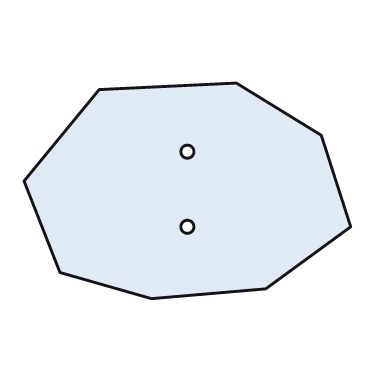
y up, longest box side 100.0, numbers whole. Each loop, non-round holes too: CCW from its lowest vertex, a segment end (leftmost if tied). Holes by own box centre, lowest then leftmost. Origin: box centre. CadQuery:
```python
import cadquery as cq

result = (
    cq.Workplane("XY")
    .moveTo(-11.0, -33.0)
    .lineTo(24.0, -30.0)
    .lineTo(50.0, -11.0)
    .lineTo(41.0, 17.0)
    .lineTo(15.0, 33.0)
    .lineTo(-27.0, 31.0)
    .lineTo(-50.0, 3.0)
    .lineTo(-39.0, -25.0)
    .close()
    .moveTo(0.0, -11.0)
    .circle(2.0)
    .moveTo(0.0, 12.0)
    .circle(2.0)
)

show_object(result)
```